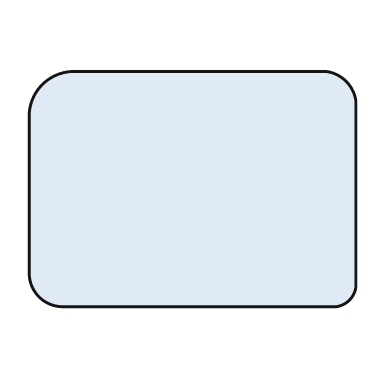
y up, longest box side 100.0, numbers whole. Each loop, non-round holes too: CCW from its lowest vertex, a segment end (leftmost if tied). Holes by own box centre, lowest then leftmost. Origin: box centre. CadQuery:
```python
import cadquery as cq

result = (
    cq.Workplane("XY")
    .moveTo(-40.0, -36.0)
    .lineTo(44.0, -36.0)
    .threePointArc((48.0, -34.0), (50.0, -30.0))
    .lineTo(50.0, 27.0)
    .threePointArc((47.0, 33.0), (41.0, 36.0))
    .lineTo(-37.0, 36.0)
    .threePointArc((-46.0, 32.0), (-50.0, 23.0))
    .lineTo(-50.0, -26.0)
    .threePointArc((-47.0, -33.0), (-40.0, -36.0))
    .close()
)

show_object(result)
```